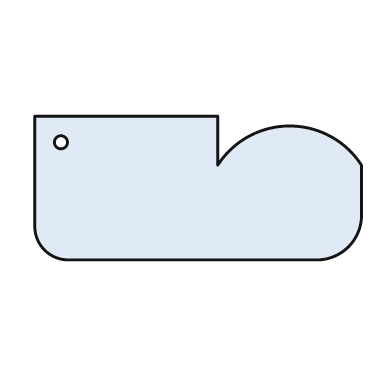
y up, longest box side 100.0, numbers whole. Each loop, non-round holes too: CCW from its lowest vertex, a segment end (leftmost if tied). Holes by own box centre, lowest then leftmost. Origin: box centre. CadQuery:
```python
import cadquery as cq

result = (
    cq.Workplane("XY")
    .moveTo(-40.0, -22.0)
    .lineTo(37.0, -22.0)
    .threePointArc((46.0, -18.0), (50.0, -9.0))
    .lineTo(50.0, 7.0)
    .threePointArc((28.0, 19.0), (6.0, 7.0))
    .lineTo(6.0, 22.0)
    .lineTo(-50.0, 22.0)
    .lineTo(-50.0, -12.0)
    .threePointArc((-47.0, -19.0), (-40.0, -22.0))
    .close()
    .moveTo(-42.0, 14.0)
    .circle(2.0)
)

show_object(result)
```